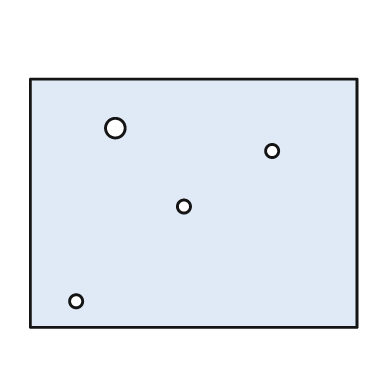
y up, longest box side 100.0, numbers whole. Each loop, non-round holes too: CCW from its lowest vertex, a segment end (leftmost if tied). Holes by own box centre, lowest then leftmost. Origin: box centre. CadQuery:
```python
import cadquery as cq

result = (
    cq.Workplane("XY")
    .moveTo(-50.0, -38.0)
    .lineTo(50.0, -38.0)
    .lineTo(50.0, 38.0)
    .lineTo(-50.0, 38.0)
    .close()
    .moveTo(-36.0, -30.0)
    .circle(2.0)
    .moveTo(-3.0, -1.0)
    .circle(2.0)
    .moveTo(24.0, 16.0)
    .circle(2.0)
    .moveTo(-24.0, 23.0)
    .circle(3.0)
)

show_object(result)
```